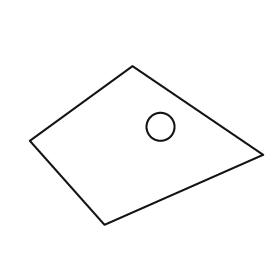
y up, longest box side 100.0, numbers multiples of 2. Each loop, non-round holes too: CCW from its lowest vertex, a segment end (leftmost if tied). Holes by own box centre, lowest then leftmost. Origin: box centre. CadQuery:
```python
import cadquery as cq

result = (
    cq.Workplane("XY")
    .moveTo(-18.0, -34.0)
    .lineTo(50.0, -4.0)
    .lineTo(-6.0, 34.0)
    .lineTo(-50.0, 2.0)
    .close()
    .moveTo(6.0, 8.0)
    .circle(6.0)
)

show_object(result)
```